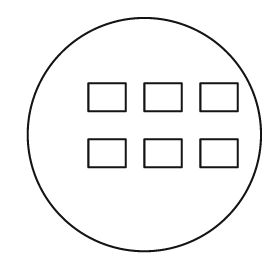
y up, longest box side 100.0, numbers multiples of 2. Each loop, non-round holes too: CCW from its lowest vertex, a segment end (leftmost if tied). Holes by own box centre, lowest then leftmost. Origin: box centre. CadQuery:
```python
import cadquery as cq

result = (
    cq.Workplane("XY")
    .moveTo(0.0, 0.0)
    .circle(50.0)
    .moveTo(-24.0, -14.0)
    .lineTo(-8.0, -14.0)
    .lineTo(-8.0, -2.0)
    .lineTo(-24.0, -2.0)
    .close()
    .moveTo(0.0, -14.0)
    .lineTo(16.0, -14.0)
    .lineTo(16.0, -2.0)
    .lineTo(0.0, -2.0)
    .close()
    .moveTo(24.0, -14.0)
    .lineTo(40.0, -14.0)
    .lineTo(40.0, -2.0)
    .lineTo(24.0, -2.0)
    .close()
    .moveTo(-24.0, 10.0)
    .lineTo(-8.0, 10.0)
    .lineTo(-8.0, 22.0)
    .lineTo(-24.0, 22.0)
    .close()
    .moveTo(0.0, 10.0)
    .lineTo(16.0, 10.0)
    .lineTo(16.0, 22.0)
    .lineTo(0.0, 22.0)
    .close()
    .moveTo(24.0, 10.0)
    .lineTo(40.0, 10.0)
    .lineTo(40.0, 22.0)
    .lineTo(24.0, 22.0)
    .close()
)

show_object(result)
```